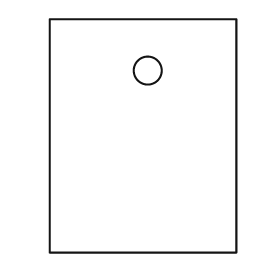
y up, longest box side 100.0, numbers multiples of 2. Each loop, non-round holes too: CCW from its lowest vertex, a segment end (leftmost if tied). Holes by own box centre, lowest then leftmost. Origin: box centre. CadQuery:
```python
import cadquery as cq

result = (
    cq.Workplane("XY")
    .moveTo(-40.0, -50.0)
    .lineTo(40.0, -50.0)
    .lineTo(40.0, 50.0)
    .lineTo(-40.0, 50.0)
    .close()
    .moveTo(2.0, 28.0)
    .circle(6.0)
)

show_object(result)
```